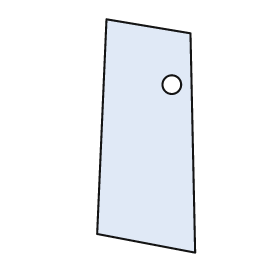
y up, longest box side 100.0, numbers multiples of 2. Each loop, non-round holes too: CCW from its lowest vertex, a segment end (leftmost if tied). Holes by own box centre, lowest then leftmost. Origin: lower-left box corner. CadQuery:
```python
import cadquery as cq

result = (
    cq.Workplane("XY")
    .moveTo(42.0, 0.0)
    .lineTo(40.0, 94.0)
    .lineTo(4.0, 100.0)
    .lineTo(0.0, 8.0)
    .close()
    .moveTo(32.0, 72.0)
    .circle(4.0)
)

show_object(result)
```